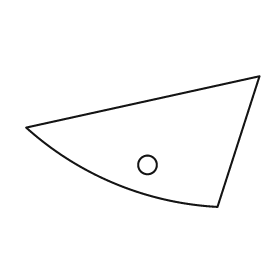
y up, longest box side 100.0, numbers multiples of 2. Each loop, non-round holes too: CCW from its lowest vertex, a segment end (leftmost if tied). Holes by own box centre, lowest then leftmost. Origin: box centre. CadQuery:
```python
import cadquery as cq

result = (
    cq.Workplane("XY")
    .moveTo(32.0, -28.0)
    .lineTo(50.0, 28.0)
    .lineTo(-50.0, 6.0)
    .threePointArc((-12.0, -18.0), (32.0, -28.0))
    .close()
    .moveTo(2.0, -10.0)
    .circle(4.0)
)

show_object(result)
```